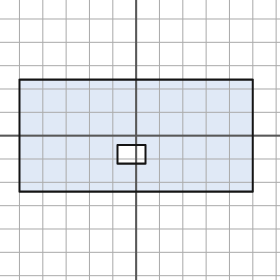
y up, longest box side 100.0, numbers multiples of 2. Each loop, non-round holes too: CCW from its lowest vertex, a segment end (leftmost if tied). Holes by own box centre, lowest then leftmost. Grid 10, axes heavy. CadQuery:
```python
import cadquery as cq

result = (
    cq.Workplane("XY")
    .moveTo(-50.0, -24.0)
    .lineTo(50.0, -24.0)
    .lineTo(50.0, 24.0)
    .lineTo(-50.0, 24.0)
    .close()
    .moveTo(-8.0, -12.0)
    .lineTo(4.0, -12.0)
    .lineTo(4.0, -4.0)
    .lineTo(-8.0, -4.0)
    .close()
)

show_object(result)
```